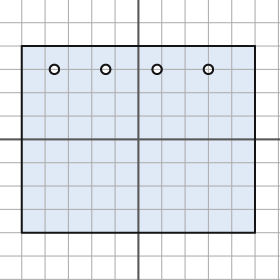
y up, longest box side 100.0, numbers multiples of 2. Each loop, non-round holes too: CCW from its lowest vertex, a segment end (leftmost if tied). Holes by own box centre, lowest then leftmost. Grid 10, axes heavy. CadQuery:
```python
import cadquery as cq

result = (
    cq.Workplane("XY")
    .moveTo(-50.0, -40.0)
    .lineTo(50.0, -40.0)
    .lineTo(50.0, 40.0)
    .lineTo(-50.0, 40.0)
    .close()
    .moveTo(-36.0, 30.0)
    .circle(2.0)
    .moveTo(-14.0, 30.0)
    .circle(2.0)
    .moveTo(8.0, 30.0)
    .circle(2.0)
    .moveTo(30.0, 30.0)
    .circle(2.0)
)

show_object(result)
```